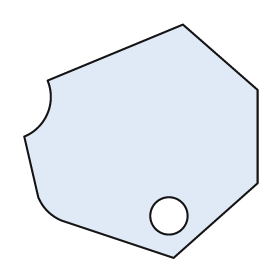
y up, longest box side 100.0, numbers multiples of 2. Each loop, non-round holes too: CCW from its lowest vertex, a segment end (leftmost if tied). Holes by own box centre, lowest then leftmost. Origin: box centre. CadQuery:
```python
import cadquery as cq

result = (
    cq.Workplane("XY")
    .moveTo(14.0, -50.0)
    .lineTo(50.0, -18.0)
    .lineTo(50.0, 22.0)
    .lineTo(18.0, 50.0)
    .lineTo(-40.0, 26.0)
    .threePointArc((-40.0, 12.0), (-50.0, 2.0))
    .lineTo(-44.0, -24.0)
    .threePointArc((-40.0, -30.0), (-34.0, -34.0))
    .close()
    .moveTo(12.0, -32.0)
    .circle(8.0)
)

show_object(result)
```